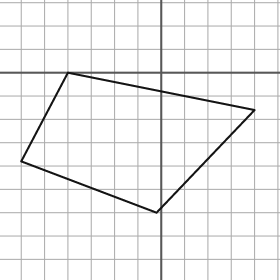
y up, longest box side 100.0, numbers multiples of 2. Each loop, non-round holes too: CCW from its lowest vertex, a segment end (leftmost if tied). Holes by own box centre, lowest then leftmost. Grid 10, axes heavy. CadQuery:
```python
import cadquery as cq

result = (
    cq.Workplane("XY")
    .moveTo(-2.0, -60.0)
    .lineTo(40.0, -16.0)
    .lineTo(-40.0, 0.0)
    .lineTo(-60.0, -38.0)
    .close()
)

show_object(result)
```